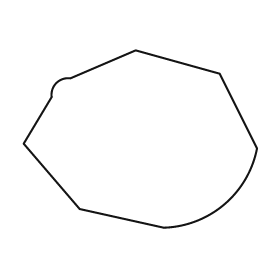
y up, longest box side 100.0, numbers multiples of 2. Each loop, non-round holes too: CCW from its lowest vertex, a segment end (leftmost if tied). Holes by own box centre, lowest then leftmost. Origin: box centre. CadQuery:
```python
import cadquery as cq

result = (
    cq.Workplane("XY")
    .moveTo(10.0, -38.0)
    .threePointArc((36.0, -28.0), (50.0, -4.0))
    .lineTo(34.0, 28.0)
    .lineTo(-2.0, 38.0)
    .lineTo(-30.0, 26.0)
    .threePointArc((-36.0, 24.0), (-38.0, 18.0))
    .lineTo(-50.0, -2.0)
    .lineTo(-26.0, -30.0)
    .close()
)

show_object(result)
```